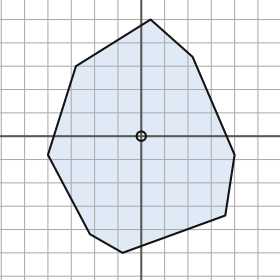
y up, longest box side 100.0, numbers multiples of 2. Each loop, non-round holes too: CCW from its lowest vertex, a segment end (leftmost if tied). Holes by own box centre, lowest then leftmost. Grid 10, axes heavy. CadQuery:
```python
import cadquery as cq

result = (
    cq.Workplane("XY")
    .moveTo(-8.0, -50.0)
    .lineTo(36.0, -34.0)
    .lineTo(40.0, -8.0)
    .lineTo(22.0, 34.0)
    .lineTo(4.0, 50.0)
    .lineTo(-28.0, 30.0)
    .lineTo(-40.0, -8.0)
    .lineTo(-22.0, -42.0)
    .close()
    .moveTo(0.0, 0.0)
    .circle(2.0)
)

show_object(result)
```